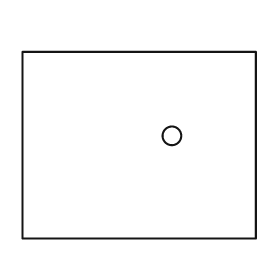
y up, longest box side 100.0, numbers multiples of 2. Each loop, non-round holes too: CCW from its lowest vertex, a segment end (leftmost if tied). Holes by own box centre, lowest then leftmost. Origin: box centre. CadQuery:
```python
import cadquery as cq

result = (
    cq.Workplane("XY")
    .moveTo(-50.0, -40.0)
    .lineTo(50.0, -40.0)
    .lineTo(50.0, 40.0)
    .lineTo(-50.0, 40.0)
    .close()
    .moveTo(14.0, 4.0)
    .circle(4.0)
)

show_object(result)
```